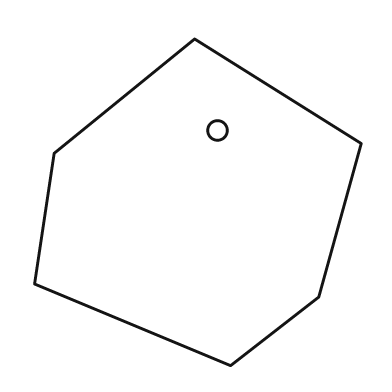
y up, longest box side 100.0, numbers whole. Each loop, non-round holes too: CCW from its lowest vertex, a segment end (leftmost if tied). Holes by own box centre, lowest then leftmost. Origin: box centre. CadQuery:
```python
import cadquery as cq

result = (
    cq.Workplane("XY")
    .moveTo(10.0, -50.0)
    .lineTo(37.0, -29.0)
    .lineTo(50.0, 18.0)
    .lineTo(-1.0, 50.0)
    .lineTo(-44.0, 15.0)
    .lineTo(-50.0, -25.0)
    .close()
    .moveTo(6.0, 22.0)
    .circle(3.0)
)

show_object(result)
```